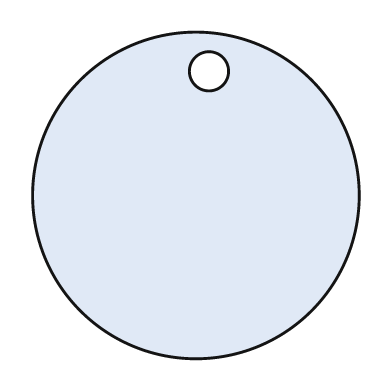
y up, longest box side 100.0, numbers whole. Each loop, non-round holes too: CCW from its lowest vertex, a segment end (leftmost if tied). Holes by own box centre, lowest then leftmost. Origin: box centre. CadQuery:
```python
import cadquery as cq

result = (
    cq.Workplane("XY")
    .moveTo(0.0, 0.0)
    .circle(50.0)
    .moveTo(4.0, 38.0)
    .circle(6.0)
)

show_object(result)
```